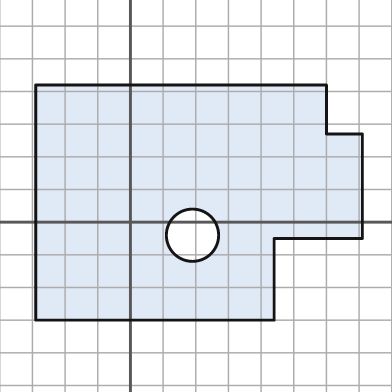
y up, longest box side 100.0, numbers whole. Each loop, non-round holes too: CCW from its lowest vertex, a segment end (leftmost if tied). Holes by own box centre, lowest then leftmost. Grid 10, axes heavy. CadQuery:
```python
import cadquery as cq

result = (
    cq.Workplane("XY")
    .moveTo(-29.0, -30.0)
    .lineTo(44.0, -30.0)
    .lineTo(44.0, -5.0)
    .lineTo(71.0, -5.0)
    .lineTo(71.0, 27.0)
    .lineTo(60.0, 27.0)
    .lineTo(60.0, 42.0)
    .lineTo(-29.0, 42.0)
    .close()
    .moveTo(19.0, -4.0)
    .circle(8.0)
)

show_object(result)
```